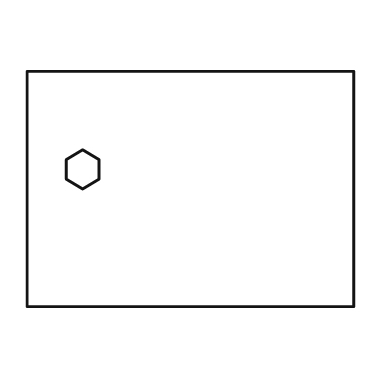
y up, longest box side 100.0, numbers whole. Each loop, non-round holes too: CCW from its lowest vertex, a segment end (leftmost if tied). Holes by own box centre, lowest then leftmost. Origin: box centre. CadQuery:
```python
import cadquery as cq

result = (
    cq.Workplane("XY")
    .moveTo(-50.0, -36.0)
    .lineTo(50.0, -36.0)
    .lineTo(50.0, 36.0)
    .lineTo(-50.0, 36.0)
    .close()
    .moveTo(-33.0, 0.0)
    .lineTo(-28.0, 3.0)
    .lineTo(-28.0, 9.0)
    .lineTo(-33.0, 12.0)
    .lineTo(-38.0, 9.0)
    .lineTo(-38.0, 3.0)
    .close()
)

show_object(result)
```